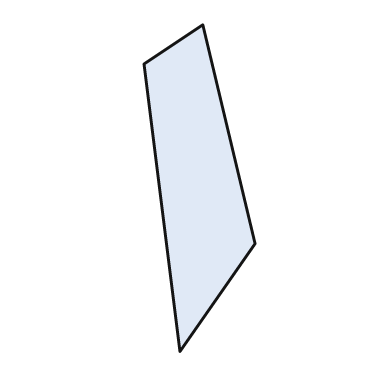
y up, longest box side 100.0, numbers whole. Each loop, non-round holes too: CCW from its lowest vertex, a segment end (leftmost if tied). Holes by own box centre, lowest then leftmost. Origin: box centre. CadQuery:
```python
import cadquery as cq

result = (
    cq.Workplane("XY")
    .moveTo(-6.0, -50.0)
    .lineTo(17.0, -17.0)
    .lineTo(1.0, 50.0)
    .lineTo(-17.0, 38.0)
    .close()
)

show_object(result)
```